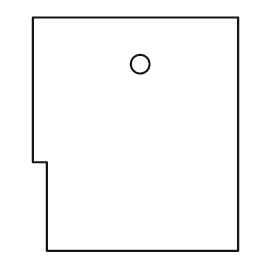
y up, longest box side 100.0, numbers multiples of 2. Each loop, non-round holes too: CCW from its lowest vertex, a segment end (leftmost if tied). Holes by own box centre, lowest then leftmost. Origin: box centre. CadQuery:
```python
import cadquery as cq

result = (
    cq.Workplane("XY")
    .moveTo(-38.0, -50.0)
    .lineTo(44.0, -50.0)
    .lineTo(44.0, 50.0)
    .lineTo(-44.0, 50.0)
    .lineTo(-44.0, -12.0)
    .lineTo(-38.0, -12.0)
    .close()
    .moveTo(2.0, 30.0)
    .circle(4.0)
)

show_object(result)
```